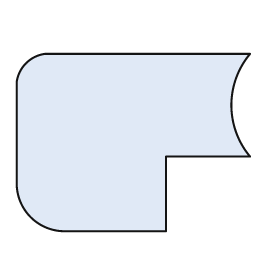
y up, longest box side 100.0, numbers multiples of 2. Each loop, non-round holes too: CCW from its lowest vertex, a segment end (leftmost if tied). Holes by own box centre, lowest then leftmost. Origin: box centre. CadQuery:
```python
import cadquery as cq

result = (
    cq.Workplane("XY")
    .moveTo(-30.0, -38.0)
    .lineTo(14.0, -38.0)
    .lineTo(14.0, -6.0)
    .lineTo(50.0, -6.0)
    .threePointArc((42.0, 16.0), (50.0, 38.0))
    .lineTo(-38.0, 38.0)
    .threePointArc((-46.0, 34.0), (-50.0, 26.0))
    .lineTo(-50.0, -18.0)
    .threePointArc((-44.0, -32.0), (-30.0, -38.0))
    .close()
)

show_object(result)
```